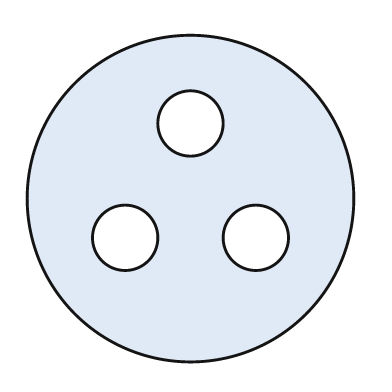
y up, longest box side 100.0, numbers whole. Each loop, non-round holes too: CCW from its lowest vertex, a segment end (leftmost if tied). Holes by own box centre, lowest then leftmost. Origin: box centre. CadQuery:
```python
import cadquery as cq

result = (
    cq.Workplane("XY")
    .moveTo(0.0, 0.0)
    .circle(50.0)
    .moveTo(-20.0, -12.0)
    .circle(10.0)
    .moveTo(20.0, -12.0)
    .circle(10.0)
    .moveTo(0.0, 23.0)
    .circle(10.0)
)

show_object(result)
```